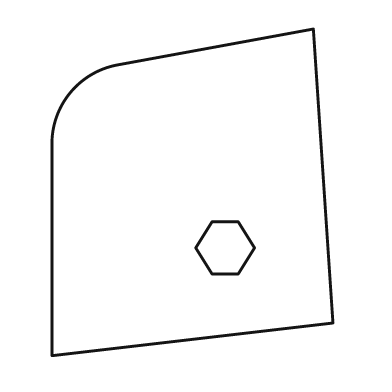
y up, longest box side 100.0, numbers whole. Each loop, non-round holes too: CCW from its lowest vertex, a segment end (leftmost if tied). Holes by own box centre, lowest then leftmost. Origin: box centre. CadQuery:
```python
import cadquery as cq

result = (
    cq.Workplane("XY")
    .moveTo(-43.0, -50.0)
    .lineTo(43.0, -40.0)
    .lineTo(37.0, 50.0)
    .lineTo(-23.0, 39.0)
    .threePointArc((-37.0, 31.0), (-43.0, 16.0))
    .close()
    .moveTo(6.0, -25.0)
    .lineTo(14.0, -25.0)
    .lineTo(19.0, -17.0)
    .lineTo(14.0, -9.0)
    .lineTo(6.0, -9.0)
    .lineTo(1.0, -17.0)
    .close()
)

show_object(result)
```